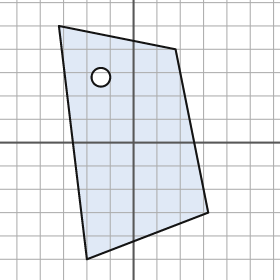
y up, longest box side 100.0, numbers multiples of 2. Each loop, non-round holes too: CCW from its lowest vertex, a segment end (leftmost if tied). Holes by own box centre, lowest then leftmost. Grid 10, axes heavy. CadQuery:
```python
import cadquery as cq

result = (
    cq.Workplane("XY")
    .moveTo(-20.0, -50.0)
    .lineTo(32.0, -30.0)
    .lineTo(18.0, 40.0)
    .lineTo(-32.0, 50.0)
    .close()
    .moveTo(-14.0, 28.0)
    .circle(4.0)
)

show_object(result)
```